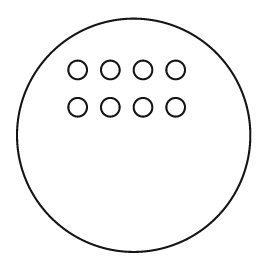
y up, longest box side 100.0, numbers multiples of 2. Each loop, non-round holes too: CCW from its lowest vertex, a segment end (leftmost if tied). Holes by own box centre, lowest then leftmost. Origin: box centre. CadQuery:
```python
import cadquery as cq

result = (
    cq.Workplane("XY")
    .moveTo(0.0, 0.0)
    .circle(50.0)
    .moveTo(-24.0, 12.0)
    .circle(4.0)
    .moveTo(-10.0, 12.0)
    .circle(4.0)
    .moveTo(4.0, 12.0)
    .circle(4.0)
    .moveTo(18.0, 12.0)
    .circle(4.0)
    .moveTo(-24.0, 28.0)
    .circle(4.0)
    .moveTo(-10.0, 28.0)
    .circle(4.0)
    .moveTo(4.0, 28.0)
    .circle(4.0)
    .moveTo(18.0, 28.0)
    .circle(4.0)
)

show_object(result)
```